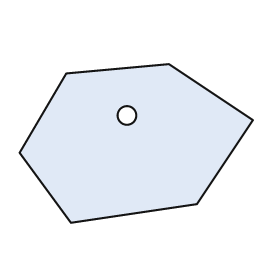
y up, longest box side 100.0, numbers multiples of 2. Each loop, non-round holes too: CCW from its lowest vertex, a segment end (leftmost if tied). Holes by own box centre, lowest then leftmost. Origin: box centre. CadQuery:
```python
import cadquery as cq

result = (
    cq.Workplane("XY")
    .moveTo(-28.0, -34.0)
    .lineTo(26.0, -26.0)
    .lineTo(50.0, 10.0)
    .lineTo(14.0, 34.0)
    .lineTo(-30.0, 30.0)
    .lineTo(-50.0, -4.0)
    .close()
    .moveTo(-4.0, 12.0)
    .circle(4.0)
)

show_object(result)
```